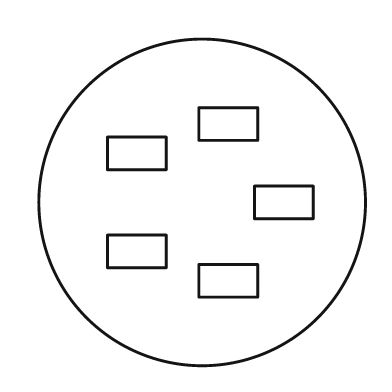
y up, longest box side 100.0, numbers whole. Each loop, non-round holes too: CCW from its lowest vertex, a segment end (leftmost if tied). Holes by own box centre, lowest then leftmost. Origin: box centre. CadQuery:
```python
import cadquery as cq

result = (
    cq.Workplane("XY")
    .moveTo(0.0, 0.0)
    .circle(50.0)
    .moveTo(-1.0, -29.0)
    .lineTo(17.0, -29.0)
    .lineTo(17.0, -19.0)
    .lineTo(-1.0, -19.0)
    .close()
    .moveTo(-29.0, -20.0)
    .lineTo(-11.0, -20.0)
    .lineTo(-11.0, -10.0)
    .lineTo(-29.0, -10.0)
    .close()
    .moveTo(16.0, -5.0)
    .lineTo(34.0, -5.0)
    .lineTo(34.0, 5.0)
    .lineTo(16.0, 5.0)
    .close()
    .moveTo(-29.0, 10.0)
    .lineTo(-11.0, 10.0)
    .lineTo(-11.0, 20.0)
    .lineTo(-29.0, 20.0)
    .close()
    .moveTo(-1.0, 19.0)
    .lineTo(17.0, 19.0)
    .lineTo(17.0, 29.0)
    .lineTo(-1.0, 29.0)
    .close()
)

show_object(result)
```